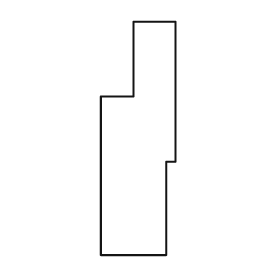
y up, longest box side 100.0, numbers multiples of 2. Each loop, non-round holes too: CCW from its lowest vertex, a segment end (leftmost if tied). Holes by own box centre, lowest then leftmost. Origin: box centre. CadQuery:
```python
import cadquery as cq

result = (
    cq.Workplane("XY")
    .moveTo(-16.0, -50.0)
    .lineTo(12.0, -50.0)
    .lineTo(12.0, -10.0)
    .lineTo(16.0, -10.0)
    .lineTo(16.0, 50.0)
    .lineTo(-2.0, 50.0)
    .lineTo(-2.0, 18.0)
    .lineTo(-16.0, 18.0)
    .close()
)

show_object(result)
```